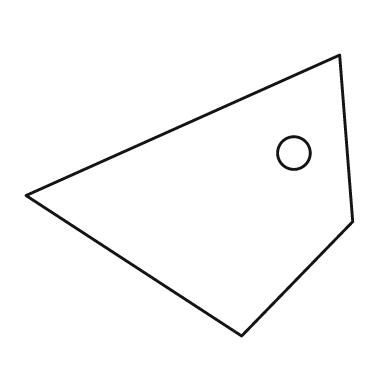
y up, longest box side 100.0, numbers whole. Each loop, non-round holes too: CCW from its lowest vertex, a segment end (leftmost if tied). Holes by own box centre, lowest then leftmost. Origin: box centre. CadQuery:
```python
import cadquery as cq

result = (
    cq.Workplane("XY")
    .moveTo(16.0, -43.0)
    .lineTo(50.0, -8.0)
    .lineTo(46.0, 43.0)
    .lineTo(-50.0, 0.0)
    .close()
    .moveTo(32.0, 13.0)
    .circle(5.0)
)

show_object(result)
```